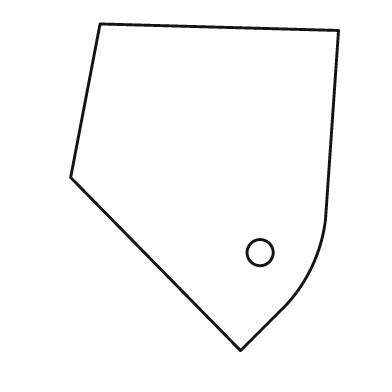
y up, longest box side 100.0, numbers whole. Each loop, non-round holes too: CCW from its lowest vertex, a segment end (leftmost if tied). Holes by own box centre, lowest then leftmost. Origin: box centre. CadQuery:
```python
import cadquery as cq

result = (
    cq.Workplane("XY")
    .moveTo(11.0, -50.0)
    .lineTo(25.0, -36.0)
    .threePointArc((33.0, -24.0), (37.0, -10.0))
    .lineTo(41.0, 48.0)
    .lineTo(-32.0, 50.0)
    .lineTo(-41.0, 3.0)
    .close()
    .moveTo(17.0, -20.0)
    .circle(4.0)
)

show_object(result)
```